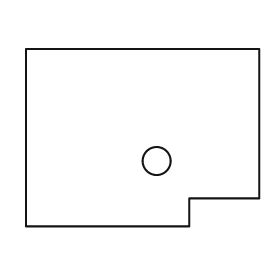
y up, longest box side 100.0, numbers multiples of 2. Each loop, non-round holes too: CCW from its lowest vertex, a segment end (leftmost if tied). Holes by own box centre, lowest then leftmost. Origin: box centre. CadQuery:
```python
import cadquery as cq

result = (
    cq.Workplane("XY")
    .moveTo(-50.0, -38.0)
    .lineTo(20.0, -38.0)
    .lineTo(20.0, -26.0)
    .lineTo(50.0, -26.0)
    .lineTo(50.0, 38.0)
    .lineTo(-50.0, 38.0)
    .close()
    .moveTo(6.0, -10.0)
    .circle(6.0)
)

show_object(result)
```